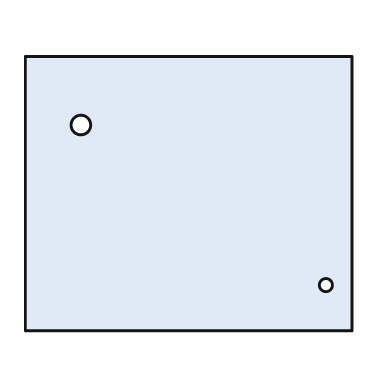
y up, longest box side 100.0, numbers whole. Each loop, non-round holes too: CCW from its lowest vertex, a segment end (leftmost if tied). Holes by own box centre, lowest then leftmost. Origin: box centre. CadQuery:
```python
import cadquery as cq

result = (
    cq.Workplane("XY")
    .moveTo(-50.0, -42.0)
    .lineTo(50.0, -42.0)
    .lineTo(50.0, 42.0)
    .lineTo(-50.0, 42.0)
    .close()
    .moveTo(42.0, -28.0)
    .circle(2.0)
    .moveTo(-33.0, 21.0)
    .circle(3.0)
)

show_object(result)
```